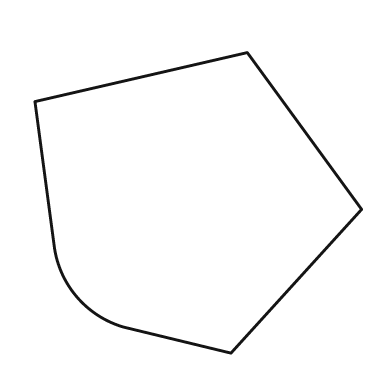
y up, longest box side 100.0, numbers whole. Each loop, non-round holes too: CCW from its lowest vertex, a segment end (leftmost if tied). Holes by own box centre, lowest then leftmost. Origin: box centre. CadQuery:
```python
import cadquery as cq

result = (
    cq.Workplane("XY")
    .moveTo(10.0, -46.0)
    .lineTo(50.0, -2.0)
    .lineTo(15.0, 46.0)
    .lineTo(-50.0, 31.0)
    .lineTo(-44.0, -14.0)
    .threePointArc((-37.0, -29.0), (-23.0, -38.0))
    .close()
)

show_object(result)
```